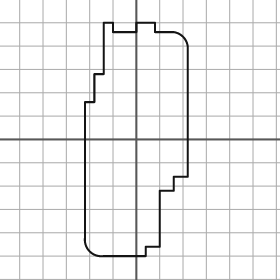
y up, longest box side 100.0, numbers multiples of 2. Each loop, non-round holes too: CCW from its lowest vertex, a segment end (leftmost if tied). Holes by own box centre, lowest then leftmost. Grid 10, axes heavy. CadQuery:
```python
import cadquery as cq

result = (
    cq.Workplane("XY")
    .moveTo(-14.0, -50.0)
    .lineTo(4.0, -50.0)
    .lineTo(4.0, -46.0)
    .lineTo(10.0, -46.0)
    .lineTo(10.0, -22.0)
    .lineTo(16.0, -22.0)
    .lineTo(16.0, -16.0)
    .lineTo(22.0, -16.0)
    .lineTo(22.0, 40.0)
    .threePointArc((20.0, 44.0), (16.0, 46.0))
    .lineTo(8.0, 46.0)
    .lineTo(8.0, 50.0)
    .lineTo(0.0, 50.0)
    .lineTo(0.0, 46.0)
    .lineTo(-10.0, 46.0)
    .lineTo(-10.0, 50.0)
    .lineTo(-14.0, 50.0)
    .lineTo(-14.0, 28.0)
    .lineTo(-18.0, 28.0)
    .lineTo(-18.0, 16.0)
    .lineTo(-22.0, 16.0)
    .lineTo(-22.0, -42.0)
    .threePointArc((-20.0, -48.0), (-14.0, -50.0))
    .close()
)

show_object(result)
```